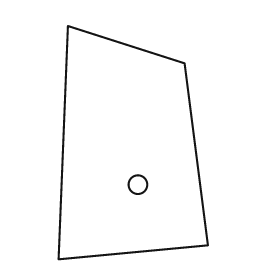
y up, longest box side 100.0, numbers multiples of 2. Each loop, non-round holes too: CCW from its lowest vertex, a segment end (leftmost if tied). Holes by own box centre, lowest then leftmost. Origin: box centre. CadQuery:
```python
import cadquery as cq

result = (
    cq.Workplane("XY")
    .moveTo(-32.0, -50.0)
    .lineTo(32.0, -44.0)
    .lineTo(22.0, 34.0)
    .lineTo(-28.0, 50.0)
    .close()
    .moveTo(2.0, -18.0)
    .circle(4.0)
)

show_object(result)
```